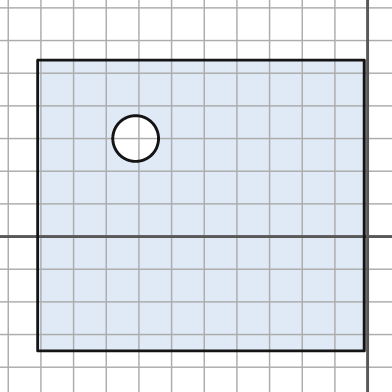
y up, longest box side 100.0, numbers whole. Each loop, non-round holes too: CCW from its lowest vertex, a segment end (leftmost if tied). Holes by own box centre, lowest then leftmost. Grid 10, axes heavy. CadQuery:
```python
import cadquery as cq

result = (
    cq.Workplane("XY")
    .moveTo(-101.0, -35.0)
    .lineTo(-1.0, -35.0)
    .lineTo(-1.0, 54.0)
    .lineTo(-101.0, 54.0)
    .close()
    .moveTo(-71.0, 30.0)
    .circle(7.0)
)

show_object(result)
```